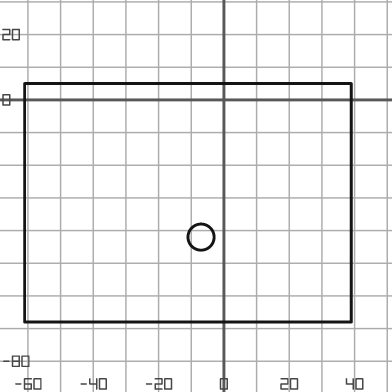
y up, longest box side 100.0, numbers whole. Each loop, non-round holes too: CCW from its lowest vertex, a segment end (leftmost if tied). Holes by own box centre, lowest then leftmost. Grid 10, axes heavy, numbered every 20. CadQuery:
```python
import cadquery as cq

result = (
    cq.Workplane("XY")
    .moveTo(-61.0, -68.0)
    .lineTo(39.0, -68.0)
    .lineTo(39.0, 5.0)
    .lineTo(-61.0, 5.0)
    .close()
    .moveTo(-7.0, -42.0)
    .circle(4.0)
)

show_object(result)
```